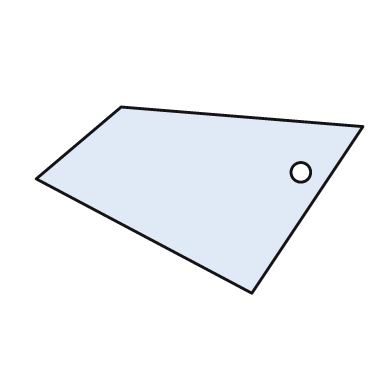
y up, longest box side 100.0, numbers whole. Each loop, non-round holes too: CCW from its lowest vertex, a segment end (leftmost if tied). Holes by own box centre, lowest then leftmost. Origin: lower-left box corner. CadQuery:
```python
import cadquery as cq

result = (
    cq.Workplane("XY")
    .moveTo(66.0, 0.0)
    .lineTo(100.0, 51.0)
    .lineTo(26.0, 57.0)
    .lineTo(0.0, 35.0)
    .close()
    .moveTo(81.0, 37.0)
    .circle(3.0)
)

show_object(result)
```